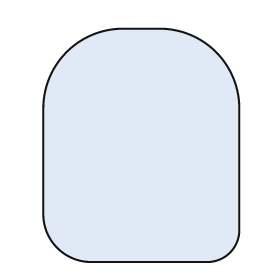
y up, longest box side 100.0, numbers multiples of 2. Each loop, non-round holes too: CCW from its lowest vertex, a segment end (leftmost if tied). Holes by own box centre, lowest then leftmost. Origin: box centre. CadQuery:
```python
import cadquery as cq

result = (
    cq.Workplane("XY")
    .moveTo(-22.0, -50.0)
    .lineTo(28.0, -50.0)
    .threePointArc((38.0, -46.0), (42.0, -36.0))
    .lineTo(42.0, 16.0)
    .threePointArc((32.0, 40.0), (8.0, 50.0))
    .lineTo(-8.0, 50.0)
    .threePointArc((-32.0, 40.0), (-42.0, 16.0))
    .lineTo(-42.0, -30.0)
    .threePointArc((-36.0, -44.0), (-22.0, -50.0))
    .close()
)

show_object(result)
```